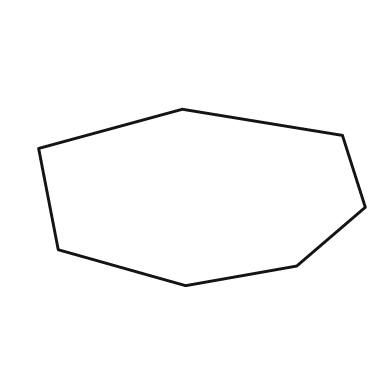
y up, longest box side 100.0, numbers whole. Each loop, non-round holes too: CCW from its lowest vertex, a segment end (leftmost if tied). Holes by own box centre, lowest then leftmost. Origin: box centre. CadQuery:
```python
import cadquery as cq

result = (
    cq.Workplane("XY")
    .moveTo(-5.0, -27.0)
    .lineTo(29.0, -21.0)
    .lineTo(50.0, -3.0)
    .lineTo(43.0, 19.0)
    .lineTo(-6.0, 27.0)
    .lineTo(-50.0, 15.0)
    .lineTo(-44.0, -16.0)
    .close()
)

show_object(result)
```